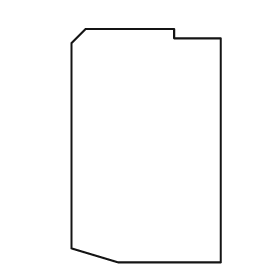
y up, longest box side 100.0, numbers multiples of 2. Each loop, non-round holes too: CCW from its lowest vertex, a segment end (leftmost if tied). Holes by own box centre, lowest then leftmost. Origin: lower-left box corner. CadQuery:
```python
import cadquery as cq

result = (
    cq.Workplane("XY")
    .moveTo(20.0, 0.0)
    .lineTo(64.0, 0.0)
    .lineTo(64.0, 96.0)
    .lineTo(44.0, 96.0)
    .lineTo(44.0, 100.0)
    .lineTo(6.0, 100.0)
    .lineTo(0.0, 94.0)
    .lineTo(0.0, 6.0)
    .close()
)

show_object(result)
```